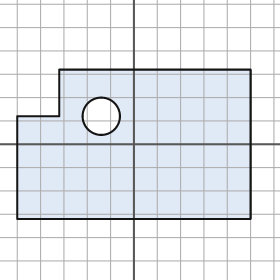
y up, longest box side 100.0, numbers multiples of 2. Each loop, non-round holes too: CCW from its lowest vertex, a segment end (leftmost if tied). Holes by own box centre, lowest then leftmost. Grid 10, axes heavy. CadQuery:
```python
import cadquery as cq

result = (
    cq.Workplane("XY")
    .moveTo(-50.0, -32.0)
    .lineTo(50.0, -32.0)
    .lineTo(50.0, 32.0)
    .lineTo(-32.0, 32.0)
    .lineTo(-32.0, 12.0)
    .lineTo(-50.0, 12.0)
    .close()
    .moveTo(-14.0, 12.0)
    .circle(8.0)
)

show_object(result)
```